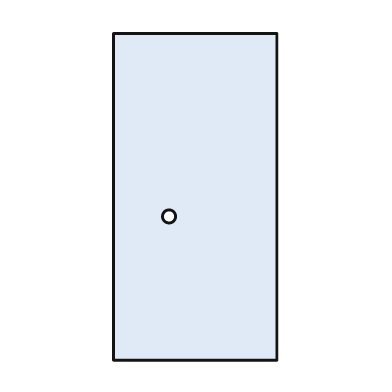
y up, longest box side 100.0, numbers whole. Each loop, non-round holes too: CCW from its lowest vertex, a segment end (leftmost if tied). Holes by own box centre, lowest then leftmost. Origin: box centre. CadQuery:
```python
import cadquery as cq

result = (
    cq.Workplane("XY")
    .moveTo(-25.0, -50.0)
    .lineTo(25.0, -50.0)
    .lineTo(25.0, 50.0)
    .lineTo(-25.0, 50.0)
    .close()
    .moveTo(-8.0, -6.0)
    .circle(2.0)
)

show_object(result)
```